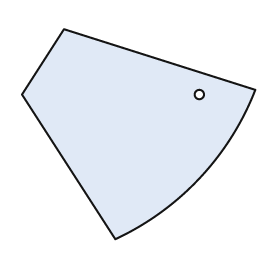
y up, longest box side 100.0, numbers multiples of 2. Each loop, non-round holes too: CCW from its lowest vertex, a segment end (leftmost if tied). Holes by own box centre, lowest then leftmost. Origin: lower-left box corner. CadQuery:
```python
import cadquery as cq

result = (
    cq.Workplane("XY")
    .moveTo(40.0, 0.0)
    .threePointArc((76.0, 26.0), (100.0, 64.0))
    .lineTo(18.0, 90.0)
    .lineTo(0.0, 62.0)
    .close()
    .moveTo(76.0, 62.0)
    .circle(2.0)
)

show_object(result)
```